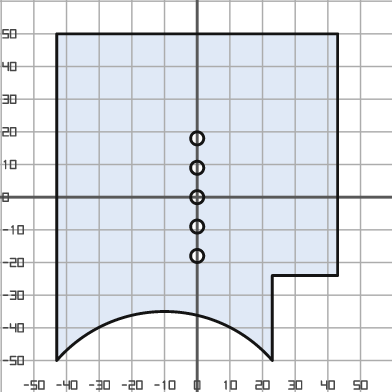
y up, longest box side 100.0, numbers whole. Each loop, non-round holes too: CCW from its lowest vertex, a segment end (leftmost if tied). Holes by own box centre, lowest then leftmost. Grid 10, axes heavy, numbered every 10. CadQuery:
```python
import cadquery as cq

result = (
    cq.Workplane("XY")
    .moveTo(-43.0, -50.0)
    .threePointArc((-10.0, -35.0), (23.0, -50.0))
    .lineTo(23.0, -24.0)
    .lineTo(43.0, -24.0)
    .lineTo(43.0, 50.0)
    .lineTo(-43.0, 50.0)
    .close()
    .moveTo(0.0, -18.0)
    .circle(2.0)
    .moveTo(0.0, -9.0)
    .circle(2.0)
    .moveTo(0.0, 0.0)
    .circle(2.0)
    .moveTo(0.0, 9.0)
    .circle(2.0)
    .moveTo(0.0, 18.0)
    .circle(2.0)
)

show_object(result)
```